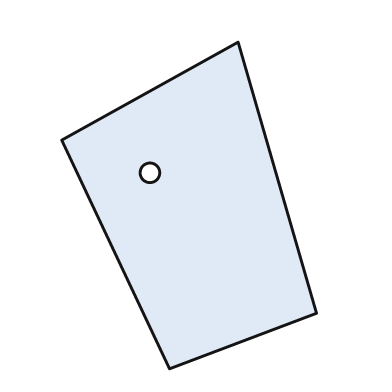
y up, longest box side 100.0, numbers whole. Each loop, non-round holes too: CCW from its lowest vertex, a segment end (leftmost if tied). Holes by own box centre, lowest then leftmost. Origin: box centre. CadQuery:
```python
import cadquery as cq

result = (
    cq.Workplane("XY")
    .moveTo(-6.0, -50.0)
    .lineTo(39.0, -33.0)
    .lineTo(15.0, 50.0)
    .lineTo(-39.0, 20.0)
    .close()
    .moveTo(-12.0, 10.0)
    .circle(3.0)
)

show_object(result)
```